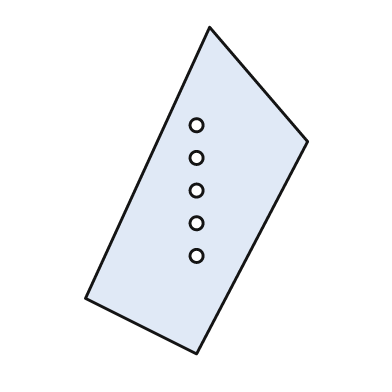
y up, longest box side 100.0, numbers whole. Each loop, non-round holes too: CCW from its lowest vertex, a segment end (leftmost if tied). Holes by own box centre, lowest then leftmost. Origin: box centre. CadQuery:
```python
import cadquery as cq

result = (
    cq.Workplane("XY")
    .moveTo(0.0, -50.0)
    .lineTo(34.0, 15.0)
    .lineTo(4.0, 50.0)
    .lineTo(-34.0, -33.0)
    .close()
    .moveTo(0.0, -20.0)
    .circle(2.0)
    .moveTo(0.0, -10.0)
    .circle(2.0)
    .moveTo(0.0, 0.0)
    .circle(2.0)
    .moveTo(0.0, 10.0)
    .circle(2.0)
    .moveTo(0.0, 20.0)
    .circle(2.0)
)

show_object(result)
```